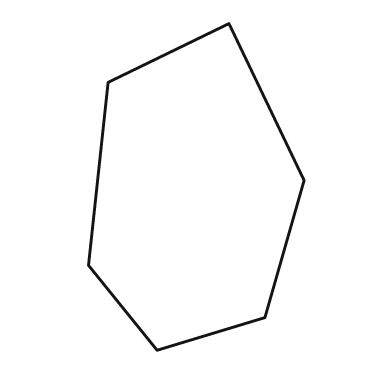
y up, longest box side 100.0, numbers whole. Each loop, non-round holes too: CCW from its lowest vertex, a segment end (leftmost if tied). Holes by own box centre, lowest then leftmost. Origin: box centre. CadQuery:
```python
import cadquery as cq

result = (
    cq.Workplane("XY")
    .moveTo(-12.0, -50.0)
    .lineTo(21.0, -40.0)
    .lineTo(33.0, 2.0)
    .lineTo(10.0, 50.0)
    .lineTo(-27.0, 32.0)
    .lineTo(-33.0, -24.0)
    .close()
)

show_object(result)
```